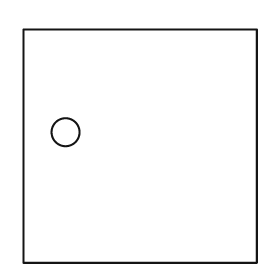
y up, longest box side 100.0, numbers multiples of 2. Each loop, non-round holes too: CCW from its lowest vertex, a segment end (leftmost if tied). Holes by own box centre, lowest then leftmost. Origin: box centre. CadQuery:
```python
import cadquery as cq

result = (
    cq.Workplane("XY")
    .moveTo(-50.0, -50.0)
    .lineTo(50.0, -50.0)
    .lineTo(50.0, 50.0)
    .lineTo(-50.0, 50.0)
    .close()
    .moveTo(-32.0, 6.0)
    .circle(6.0)
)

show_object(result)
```